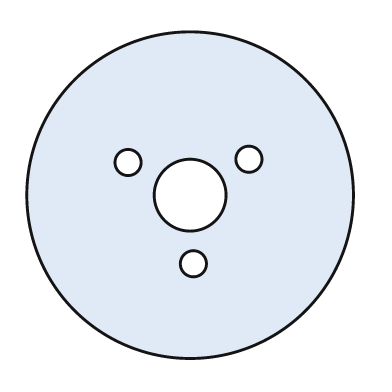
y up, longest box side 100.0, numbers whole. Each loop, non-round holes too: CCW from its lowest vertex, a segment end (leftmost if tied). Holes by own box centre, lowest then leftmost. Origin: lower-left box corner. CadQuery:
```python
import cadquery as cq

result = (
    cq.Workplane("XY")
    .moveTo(50.0, 50.0)
    .circle(50.0)
    .moveTo(51.0, 29.0)
    .circle(4.0)
    .moveTo(50.0, 50.0)
    .circle(11.0)
    .moveTo(31.0, 60.0)
    .circle(4.0)
    .moveTo(68.0, 61.0)
    .circle(4.0)
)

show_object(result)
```